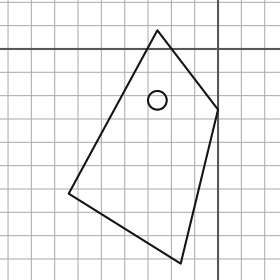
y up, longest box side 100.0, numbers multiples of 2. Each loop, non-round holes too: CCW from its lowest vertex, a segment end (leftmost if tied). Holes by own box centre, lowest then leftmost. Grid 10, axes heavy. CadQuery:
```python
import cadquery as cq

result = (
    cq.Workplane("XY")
    .moveTo(-16.0, -92.0)
    .lineTo(0.0, -26.0)
    .lineTo(-26.0, 8.0)
    .lineTo(-64.0, -62.0)
    .close()
    .moveTo(-26.0, -22.0)
    .circle(4.0)
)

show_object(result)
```